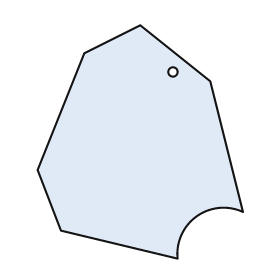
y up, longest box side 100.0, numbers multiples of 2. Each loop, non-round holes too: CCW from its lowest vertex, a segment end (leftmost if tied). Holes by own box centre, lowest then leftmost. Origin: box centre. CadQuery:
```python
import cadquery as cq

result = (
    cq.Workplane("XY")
    .moveTo(16.0, -50.0)
    .threePointArc((24.0, -32.0), (44.0, -30.0))
    .lineTo(30.0, 26.0)
    .lineTo(0.0, 50.0)
    .lineTo(-24.0, 38.0)
    .lineTo(-44.0, -12.0)
    .lineTo(-34.0, -38.0)
    .close()
    .moveTo(14.0, 30.0)
    .circle(2.0)
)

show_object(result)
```